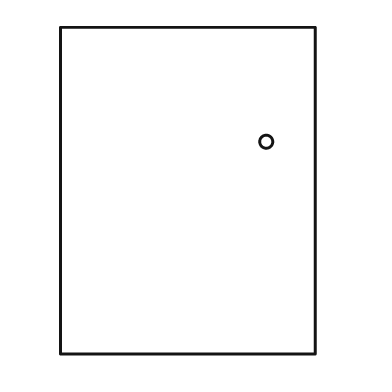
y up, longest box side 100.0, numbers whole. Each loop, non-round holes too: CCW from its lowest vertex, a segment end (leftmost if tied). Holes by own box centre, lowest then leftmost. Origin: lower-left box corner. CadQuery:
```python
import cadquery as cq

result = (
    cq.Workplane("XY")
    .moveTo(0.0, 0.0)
    .lineTo(78.0, 0.0)
    .lineTo(78.0, 100.0)
    .lineTo(0.0, 100.0)
    .close()
    .moveTo(63.0, 65.0)
    .circle(2.0)
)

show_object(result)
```